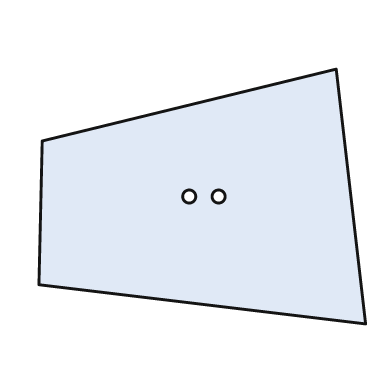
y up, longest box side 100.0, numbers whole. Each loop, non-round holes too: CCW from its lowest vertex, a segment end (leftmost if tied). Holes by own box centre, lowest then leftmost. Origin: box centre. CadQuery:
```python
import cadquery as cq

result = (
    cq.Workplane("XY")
    .moveTo(50.0, -39.0)
    .lineTo(41.0, 39.0)
    .lineTo(-49.0, 17.0)
    .lineTo(-50.0, -27.0)
    .close()
    .moveTo(-4.0, 0.0)
    .circle(2.0)
    .moveTo(5.0, 0.0)
    .circle(2.0)
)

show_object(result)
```